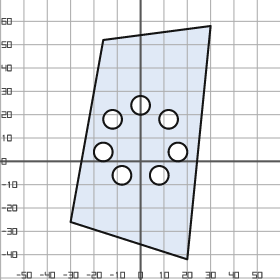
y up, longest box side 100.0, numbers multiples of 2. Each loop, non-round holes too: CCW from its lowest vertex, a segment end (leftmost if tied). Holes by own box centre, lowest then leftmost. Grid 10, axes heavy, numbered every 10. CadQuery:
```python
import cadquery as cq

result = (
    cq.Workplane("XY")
    .moveTo(20.0, -42.0)
    .lineTo(30.0, 58.0)
    .lineTo(-16.0, 52.0)
    .lineTo(-30.0, -26.0)
    .close()
    .moveTo(-8.0, -6.0)
    .circle(4.0)
    .moveTo(8.0, -6.0)
    .circle(4.0)
    .moveTo(-16.0, 4.0)
    .circle(4.0)
    .moveTo(16.0, 4.0)
    .circle(4.0)
    .moveTo(-12.0, 18.0)
    .circle(4.0)
    .moveTo(12.0, 18.0)
    .circle(4.0)
    .moveTo(0.0, 24.0)
    .circle(4.0)
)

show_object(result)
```